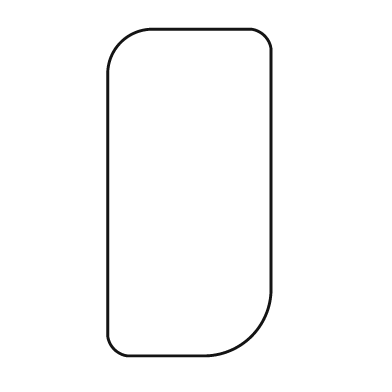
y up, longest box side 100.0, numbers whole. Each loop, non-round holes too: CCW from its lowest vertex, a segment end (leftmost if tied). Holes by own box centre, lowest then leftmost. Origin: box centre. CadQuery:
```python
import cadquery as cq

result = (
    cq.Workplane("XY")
    .moveTo(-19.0, -50.0)
    .lineTo(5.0, -50.0)
    .threePointArc((19.0, -44.0), (25.0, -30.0))
    .lineTo(25.0, 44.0)
    .threePointArc((23.0, 48.0), (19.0, 50.0))
    .lineTo(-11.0, 50.0)
    .threePointArc((-21.0, 46.0), (-25.0, 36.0))
    .lineTo(-25.0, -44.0)
    .threePointArc((-23.0, -48.0), (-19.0, -50.0))
    .close()
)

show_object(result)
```